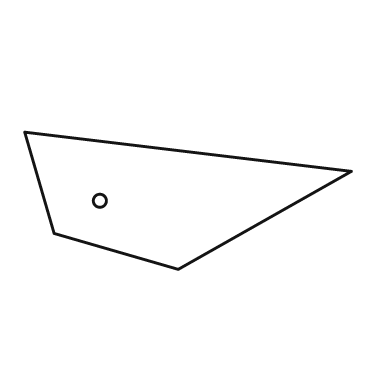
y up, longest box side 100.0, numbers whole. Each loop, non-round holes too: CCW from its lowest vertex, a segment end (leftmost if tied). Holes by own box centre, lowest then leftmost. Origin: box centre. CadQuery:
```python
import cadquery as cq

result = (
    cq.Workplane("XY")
    .moveTo(-3.0, -21.0)
    .lineTo(50.0, 9.0)
    .lineTo(-50.0, 21.0)
    .lineTo(-41.0, -10.0)
    .close()
    .moveTo(-27.0, 0.0)
    .circle(2.0)
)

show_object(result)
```